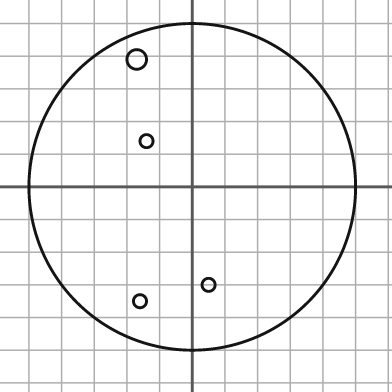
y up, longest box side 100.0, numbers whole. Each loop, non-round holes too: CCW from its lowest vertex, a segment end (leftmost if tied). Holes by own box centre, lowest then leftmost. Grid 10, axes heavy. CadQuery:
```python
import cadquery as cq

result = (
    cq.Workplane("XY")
    .moveTo(0.0, 0.0)
    .circle(50.0)
    .moveTo(-16.0, -35.0)
    .circle(2.0)
    .moveTo(5.0, -30.0)
    .circle(2.0)
    .moveTo(-14.0, 14.0)
    .circle(2.0)
    .moveTo(-17.0, 39.0)
    .circle(3.0)
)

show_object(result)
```